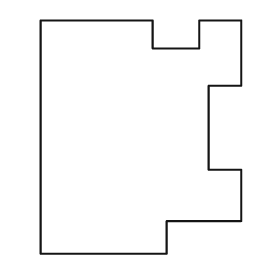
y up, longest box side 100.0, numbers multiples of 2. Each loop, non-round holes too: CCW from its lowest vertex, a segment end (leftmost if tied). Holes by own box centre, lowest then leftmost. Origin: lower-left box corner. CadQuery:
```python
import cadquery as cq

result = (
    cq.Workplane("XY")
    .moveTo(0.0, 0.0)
    .lineTo(54.0, 0.0)
    .lineTo(54.0, 14.0)
    .lineTo(86.0, 14.0)
    .lineTo(86.0, 36.0)
    .lineTo(72.0, 36.0)
    .lineTo(72.0, 72.0)
    .lineTo(86.0, 72.0)
    .lineTo(86.0, 100.0)
    .lineTo(68.0, 100.0)
    .lineTo(68.0, 88.0)
    .lineTo(48.0, 88.0)
    .lineTo(48.0, 100.0)
    .lineTo(0.0, 100.0)
    .close()
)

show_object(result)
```